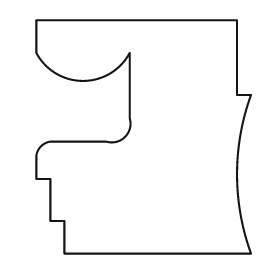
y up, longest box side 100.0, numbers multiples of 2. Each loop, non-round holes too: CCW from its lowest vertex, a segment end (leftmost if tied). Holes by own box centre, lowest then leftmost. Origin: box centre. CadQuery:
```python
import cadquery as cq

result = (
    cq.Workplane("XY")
    .moveTo(-34.0, -50.0)
    .lineTo(46.0, -50.0)
    .threePointArc((40.0, -16.0), (46.0, 18.0))
    .lineTo(40.0, 18.0)
    .lineTo(40.0, 50.0)
    .lineTo(-46.0, 50.0)
    .lineTo(-46.0, 36.0)
    .threePointArc((-26.0, 24.0), (-6.0, 36.0))
    .lineTo(-6.0, 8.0)
    .threePointArc((-8.0, 0.0), (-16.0, -2.0))
    .lineTo(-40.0, -2.0)
    .threePointArc((-44.0, -4.0), (-46.0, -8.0))
    .lineTo(-46.0, -18.0)
    .lineTo(-40.0, -18.0)
    .lineTo(-40.0, -36.0)
    .lineTo(-34.0, -36.0)
    .close()
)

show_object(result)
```